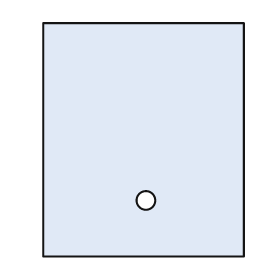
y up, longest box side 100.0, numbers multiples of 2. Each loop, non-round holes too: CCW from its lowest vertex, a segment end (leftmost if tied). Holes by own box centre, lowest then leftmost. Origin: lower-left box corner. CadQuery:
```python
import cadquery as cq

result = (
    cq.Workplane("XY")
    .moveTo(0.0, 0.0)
    .lineTo(86.0, 0.0)
    .lineTo(86.0, 100.0)
    .lineTo(0.0, 100.0)
    .close()
    .moveTo(44.0, 24.0)
    .circle(4.0)
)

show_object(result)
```